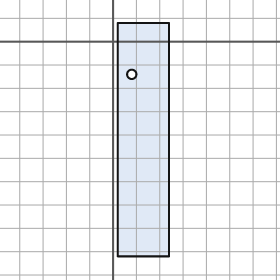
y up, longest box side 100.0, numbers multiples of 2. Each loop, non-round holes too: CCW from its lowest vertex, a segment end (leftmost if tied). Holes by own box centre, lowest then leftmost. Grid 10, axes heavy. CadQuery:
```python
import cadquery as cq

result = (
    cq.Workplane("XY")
    .moveTo(2.0, -92.0)
    .lineTo(24.0, -92.0)
    .lineTo(24.0, 8.0)
    .lineTo(2.0, 8.0)
    .close()
    .moveTo(8.0, -14.0)
    .circle(2.0)
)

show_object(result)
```